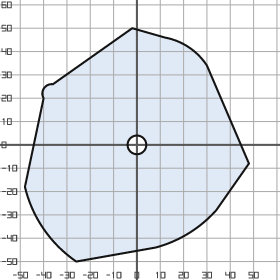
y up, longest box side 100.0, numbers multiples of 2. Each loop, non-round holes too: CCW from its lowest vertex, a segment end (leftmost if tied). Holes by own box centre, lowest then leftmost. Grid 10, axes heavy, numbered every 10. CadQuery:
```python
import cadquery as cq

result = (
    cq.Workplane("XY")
    .moveTo(-26.0, -50.0)
    .lineTo(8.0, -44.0)
    .threePointArc((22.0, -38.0), (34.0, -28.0))
    .lineTo(48.0, -8.0)
    .lineTo(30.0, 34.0)
    .threePointArc((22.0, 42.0), (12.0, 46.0))
    .lineTo(-2.0, 50.0)
    .lineTo(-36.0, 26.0)
    .threePointArc((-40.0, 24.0), (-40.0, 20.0))
    .lineTo(-48.0, -18.0)
    .threePointArc((-40.0, -36.0), (-26.0, -50.0))
    .close()
    .moveTo(0.0, 0.0)
    .circle(4.0)
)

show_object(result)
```